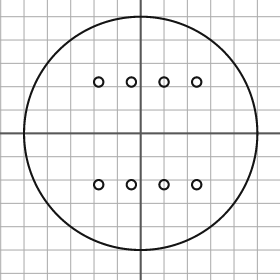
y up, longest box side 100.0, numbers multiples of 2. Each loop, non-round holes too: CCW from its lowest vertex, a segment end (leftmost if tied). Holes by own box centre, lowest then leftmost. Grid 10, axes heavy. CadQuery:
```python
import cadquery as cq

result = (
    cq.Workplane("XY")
    .moveTo(0.0, 0.0)
    .circle(50.0)
    .moveTo(-18.0, -22.0)
    .circle(2.0)
    .moveTo(-4.0, -22.0)
    .circle(2.0)
    .moveTo(10.0, -22.0)
    .circle(2.0)
    .moveTo(24.0, -22.0)
    .circle(2.0)
    .moveTo(-18.0, 22.0)
    .circle(2.0)
    .moveTo(-4.0, 22.0)
    .circle(2.0)
    .moveTo(10.0, 22.0)
    .circle(2.0)
    .moveTo(24.0, 22.0)
    .circle(2.0)
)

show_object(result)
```